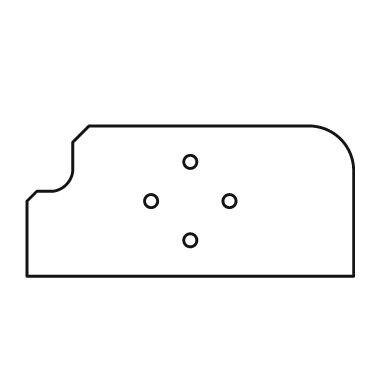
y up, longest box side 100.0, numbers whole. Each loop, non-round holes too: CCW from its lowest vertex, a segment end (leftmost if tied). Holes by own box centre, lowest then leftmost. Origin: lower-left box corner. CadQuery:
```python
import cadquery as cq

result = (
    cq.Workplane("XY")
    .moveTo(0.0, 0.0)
    .lineTo(100.0, 0.0)
    .lineTo(100.0, 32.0)
    .threePointArc((96.0, 42.0), (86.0, 46.0))
    .lineTo(19.0, 46.0)
    .lineTo(14.0, 41.0)
    .lineTo(14.0, 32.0)
    .threePointArc((12.0, 28.0), (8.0, 26.0))
    .lineTo(3.0, 26.0)
    .lineTo(0.0, 23.0)
    .close()
    .moveTo(50.0, 11.0)
    .circle(2.0)
    .moveTo(38.0, 23.0)
    .circle(2.0)
    .moveTo(62.0, 23.0)
    .circle(2.0)
    .moveTo(50.0, 35.0)
    .circle(2.0)
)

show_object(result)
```